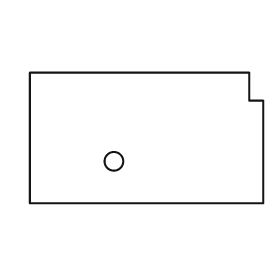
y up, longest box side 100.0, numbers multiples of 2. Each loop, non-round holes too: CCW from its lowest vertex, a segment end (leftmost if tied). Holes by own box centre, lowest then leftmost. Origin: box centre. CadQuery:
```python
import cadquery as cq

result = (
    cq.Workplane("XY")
    .moveTo(-50.0, -28.0)
    .lineTo(50.0, -28.0)
    .lineTo(50.0, 16.0)
    .lineTo(44.0, 16.0)
    .lineTo(44.0, 28.0)
    .lineTo(-50.0, 28.0)
    .close()
    .moveTo(-14.0, -10.0)
    .circle(4.0)
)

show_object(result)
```